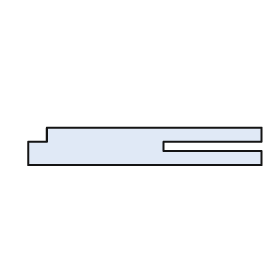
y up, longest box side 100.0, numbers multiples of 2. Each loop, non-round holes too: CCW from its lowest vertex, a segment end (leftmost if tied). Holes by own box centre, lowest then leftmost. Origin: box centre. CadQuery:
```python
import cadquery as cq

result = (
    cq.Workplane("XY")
    .moveTo(-50.0, -8.0)
    .lineTo(50.0, -8.0)
    .lineTo(50.0, -2.0)
    .lineTo(8.0, -2.0)
    .lineTo(8.0, 2.0)
    .lineTo(50.0, 2.0)
    .lineTo(50.0, 8.0)
    .lineTo(-42.0, 8.0)
    .lineTo(-42.0, 2.0)
    .lineTo(-50.0, 2.0)
    .close()
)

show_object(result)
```